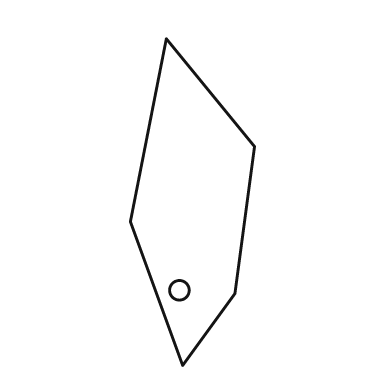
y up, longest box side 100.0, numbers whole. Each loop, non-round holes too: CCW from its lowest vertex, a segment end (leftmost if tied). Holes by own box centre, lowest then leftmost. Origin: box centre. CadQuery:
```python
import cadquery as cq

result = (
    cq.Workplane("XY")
    .moveTo(-3.0, -50.0)
    .lineTo(13.0, -28.0)
    .lineTo(19.0, 17.0)
    .lineTo(-8.0, 50.0)
    .lineTo(-19.0, -6.0)
    .close()
    .moveTo(-4.0, -27.0)
    .circle(3.0)
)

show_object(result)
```